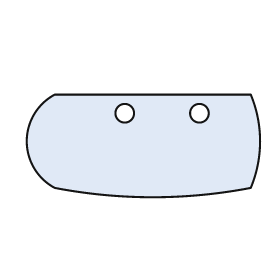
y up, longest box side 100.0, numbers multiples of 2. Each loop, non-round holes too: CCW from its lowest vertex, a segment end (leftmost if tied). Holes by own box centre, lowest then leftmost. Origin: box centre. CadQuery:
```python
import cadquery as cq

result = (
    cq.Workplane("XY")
    .moveTo(-38.0, -18.0)
    .threePointArc((4.0, -22.0), (46.0, -18.0))
    .threePointArc((50.0, 2.0), (46.0, 22.0))
    .lineTo(-38.0, 22.0)
    .threePointArc((-50.0, 2.0), (-38.0, -18.0))
    .close()
    .moveTo(-8.0, 14.0)
    .circle(4.0)
    .moveTo(24.0, 14.0)
    .circle(4.0)
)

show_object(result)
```